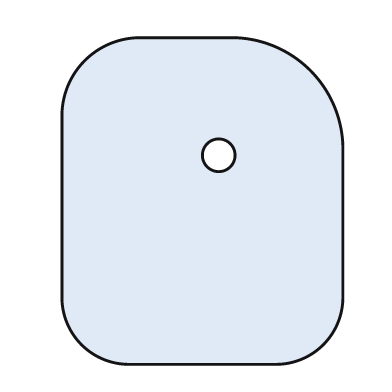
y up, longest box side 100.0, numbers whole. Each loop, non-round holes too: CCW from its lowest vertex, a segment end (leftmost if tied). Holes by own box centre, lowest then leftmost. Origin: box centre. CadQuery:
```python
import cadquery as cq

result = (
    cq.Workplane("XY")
    .moveTo(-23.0, -50.0)
    .lineTo(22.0, -50.0)
    .threePointArc((37.0, -44.0), (43.0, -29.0))
    .lineTo(43.0, 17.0)
    .threePointArc((33.0, 40.0), (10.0, 50.0))
    .lineTo(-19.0, 50.0)
    .threePointArc((-36.0, 43.0), (-43.0, 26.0))
    .lineTo(-43.0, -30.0)
    .threePointArc((-37.0, -44.0), (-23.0, -50.0))
    .close()
    .moveTo(5.0, 14.0)
    .circle(5.0)
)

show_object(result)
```